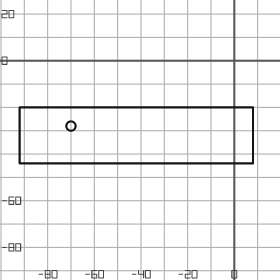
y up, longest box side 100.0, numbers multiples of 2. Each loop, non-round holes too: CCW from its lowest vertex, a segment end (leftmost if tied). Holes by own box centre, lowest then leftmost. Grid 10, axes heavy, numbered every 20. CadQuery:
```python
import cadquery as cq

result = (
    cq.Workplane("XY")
    .moveTo(-92.0, -44.0)
    .lineTo(8.0, -44.0)
    .lineTo(8.0, -20.0)
    .lineTo(-92.0, -20.0)
    .close()
    .moveTo(-70.0, -28.0)
    .circle(2.0)
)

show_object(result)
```